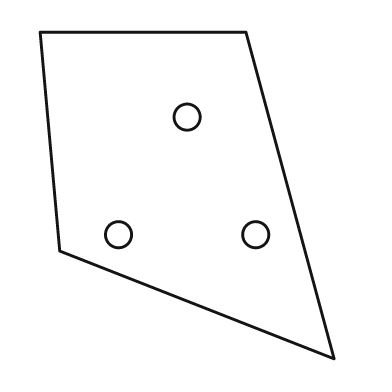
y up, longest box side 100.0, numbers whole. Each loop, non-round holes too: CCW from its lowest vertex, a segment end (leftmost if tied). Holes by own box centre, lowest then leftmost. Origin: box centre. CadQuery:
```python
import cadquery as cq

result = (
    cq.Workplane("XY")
    .moveTo(45.0, -50.0)
    .lineTo(18.0, 50.0)
    .lineTo(-45.0, 50.0)
    .lineTo(-39.0, -17.0)
    .close()
    .moveTo(-21.0, -12.0)
    .circle(4.0)
    .moveTo(21.0, -12.0)
    .circle(4.0)
    .moveTo(0.0, 24.0)
    .circle(4.0)
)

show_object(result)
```